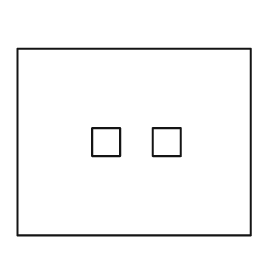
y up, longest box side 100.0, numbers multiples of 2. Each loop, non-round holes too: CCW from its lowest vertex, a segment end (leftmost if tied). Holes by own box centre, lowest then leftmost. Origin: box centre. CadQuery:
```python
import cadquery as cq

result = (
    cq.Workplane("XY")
    .moveTo(-50.0, -40.0)
    .lineTo(50.0, -40.0)
    .lineTo(50.0, 40.0)
    .lineTo(-50.0, 40.0)
    .close()
    .moveTo(-18.0, -6.0)
    .lineTo(-6.0, -6.0)
    .lineTo(-6.0, 6.0)
    .lineTo(-18.0, 6.0)
    .close()
    .moveTo(8.0, -6.0)
    .lineTo(20.0, -6.0)
    .lineTo(20.0, 6.0)
    .lineTo(8.0, 6.0)
    .close()
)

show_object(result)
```